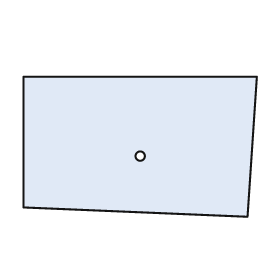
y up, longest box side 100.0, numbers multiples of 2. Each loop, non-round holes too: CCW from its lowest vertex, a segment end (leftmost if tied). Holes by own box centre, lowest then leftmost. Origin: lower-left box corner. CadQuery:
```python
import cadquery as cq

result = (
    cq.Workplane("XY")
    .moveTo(96.0, 0.0)
    .lineTo(100.0, 60.0)
    .lineTo(0.0, 60.0)
    .lineTo(0.0, 4.0)
    .close()
    .moveTo(50.0, 26.0)
    .circle(2.0)
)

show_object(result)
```